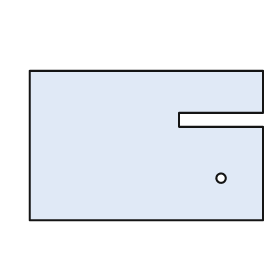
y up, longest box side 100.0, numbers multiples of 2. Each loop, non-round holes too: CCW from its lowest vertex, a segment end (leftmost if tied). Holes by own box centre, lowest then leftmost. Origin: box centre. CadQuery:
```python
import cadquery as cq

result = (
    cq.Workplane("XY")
    .moveTo(-50.0, -32.0)
    .lineTo(50.0, -32.0)
    .lineTo(50.0, 8.0)
    .lineTo(14.0, 8.0)
    .lineTo(14.0, 14.0)
    .lineTo(50.0, 14.0)
    .lineTo(50.0, 32.0)
    .lineTo(-50.0, 32.0)
    .close()
    .moveTo(32.0, -14.0)
    .circle(2.0)
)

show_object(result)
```